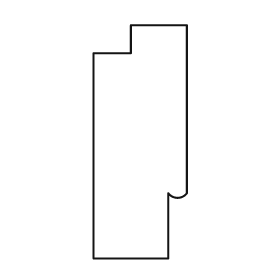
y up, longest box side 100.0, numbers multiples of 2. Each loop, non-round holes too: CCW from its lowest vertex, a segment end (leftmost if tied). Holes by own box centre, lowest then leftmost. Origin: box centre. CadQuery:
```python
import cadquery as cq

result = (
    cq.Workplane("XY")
    .moveTo(-20.0, -50.0)
    .lineTo(12.0, -50.0)
    .lineTo(12.0, -22.0)
    .threePointArc((16.0, -24.0), (20.0, -22.0))
    .lineTo(20.0, 50.0)
    .lineTo(-4.0, 50.0)
    .lineTo(-4.0, 38.0)
    .lineTo(-20.0, 38.0)
    .close()
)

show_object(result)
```